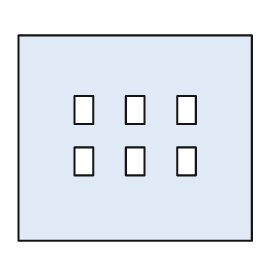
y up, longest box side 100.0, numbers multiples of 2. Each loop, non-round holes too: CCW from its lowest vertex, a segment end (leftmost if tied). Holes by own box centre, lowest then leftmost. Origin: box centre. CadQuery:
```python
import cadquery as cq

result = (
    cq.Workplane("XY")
    .moveTo(-50.0, -44.0)
    .lineTo(50.0, -44.0)
    .lineTo(50.0, 44.0)
    .lineTo(-50.0, 44.0)
    .close()
    .moveTo(-26.0, -16.0)
    .lineTo(-18.0, -16.0)
    .lineTo(-18.0, -4.0)
    .lineTo(-26.0, -4.0)
    .close()
    .moveTo(-4.0, -16.0)
    .lineTo(4.0, -16.0)
    .lineTo(4.0, -4.0)
    .lineTo(-4.0, -4.0)
    .close()
    .moveTo(18.0, -16.0)
    .lineTo(26.0, -16.0)
    .lineTo(26.0, -4.0)
    .lineTo(18.0, -4.0)
    .close()
    .moveTo(-26.0, 6.0)
    .lineTo(-18.0, 6.0)
    .lineTo(-18.0, 18.0)
    .lineTo(-26.0, 18.0)
    .close()
    .moveTo(-4.0, 6.0)
    .lineTo(4.0, 6.0)
    .lineTo(4.0, 18.0)
    .lineTo(-4.0, 18.0)
    .close()
    .moveTo(18.0, 6.0)
    .lineTo(26.0, 6.0)
    .lineTo(26.0, 18.0)
    .lineTo(18.0, 18.0)
    .close()
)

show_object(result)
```